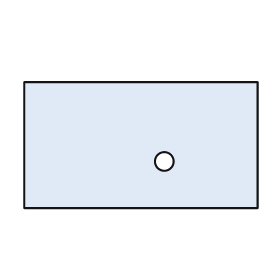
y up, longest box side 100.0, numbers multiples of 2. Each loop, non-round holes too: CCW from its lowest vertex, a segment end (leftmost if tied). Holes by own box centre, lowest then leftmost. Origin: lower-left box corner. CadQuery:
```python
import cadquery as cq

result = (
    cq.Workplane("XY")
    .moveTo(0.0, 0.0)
    .lineTo(100.0, 0.0)
    .lineTo(100.0, 54.0)
    .lineTo(0.0, 54.0)
    .close()
    .moveTo(60.0, 20.0)
    .circle(4.0)
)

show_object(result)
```